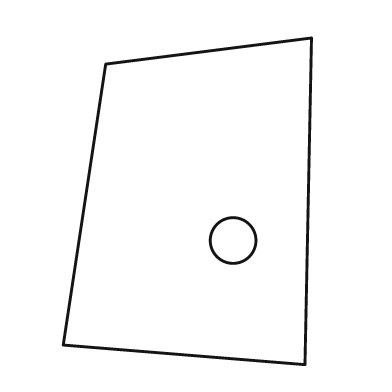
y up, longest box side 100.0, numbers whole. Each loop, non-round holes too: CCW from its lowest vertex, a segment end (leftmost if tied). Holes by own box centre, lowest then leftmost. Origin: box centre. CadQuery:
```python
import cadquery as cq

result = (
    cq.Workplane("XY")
    .moveTo(36.0, -50.0)
    .lineTo(38.0, 50.0)
    .lineTo(-25.0, 42.0)
    .lineTo(-38.0, -44.0)
    .close()
    .moveTo(14.0, -12.0)
    .circle(7.0)
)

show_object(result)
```